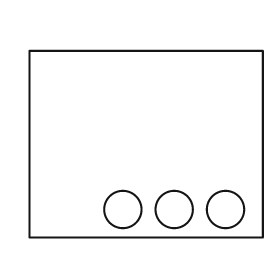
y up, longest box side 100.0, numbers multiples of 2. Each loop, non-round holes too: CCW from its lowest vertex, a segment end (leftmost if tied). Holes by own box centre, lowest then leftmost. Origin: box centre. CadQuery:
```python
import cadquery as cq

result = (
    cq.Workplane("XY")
    .moveTo(-50.0, -40.0)
    .lineTo(50.0, -40.0)
    .lineTo(50.0, 40.0)
    .lineTo(-50.0, 40.0)
    .close()
    .moveTo(-10.0, -28.0)
    .circle(8.0)
    .moveTo(12.0, -28.0)
    .circle(8.0)
    .moveTo(34.0, -28.0)
    .circle(8.0)
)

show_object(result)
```